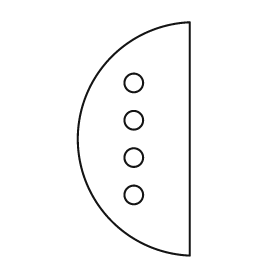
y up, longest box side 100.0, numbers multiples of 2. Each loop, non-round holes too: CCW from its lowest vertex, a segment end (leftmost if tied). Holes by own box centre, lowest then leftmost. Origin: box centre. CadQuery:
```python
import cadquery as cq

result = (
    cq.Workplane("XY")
    .moveTo(24.0, -50.0)
    .lineTo(24.0, 50.0)
    .threePointArc((-24.0, 0.0), (24.0, -50.0))
    .close()
    .moveTo(0.0, -24.0)
    .circle(4.0)
    .moveTo(0.0, -8.0)
    .circle(4.0)
    .moveTo(0.0, 8.0)
    .circle(4.0)
    .moveTo(0.0, 24.0)
    .circle(4.0)
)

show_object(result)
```